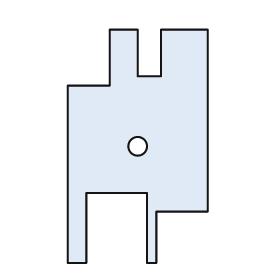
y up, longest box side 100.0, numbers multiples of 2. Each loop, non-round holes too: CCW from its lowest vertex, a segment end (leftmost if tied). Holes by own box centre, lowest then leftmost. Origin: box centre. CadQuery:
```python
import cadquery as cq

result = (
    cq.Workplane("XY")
    .moveTo(-30.0, -50.0)
    .lineTo(-22.0, -50.0)
    .lineTo(-22.0, -20.0)
    .lineTo(4.0, -20.0)
    .lineTo(4.0, -50.0)
    .lineTo(8.0, -50.0)
    .lineTo(8.0, -28.0)
    .lineTo(30.0, -28.0)
    .lineTo(30.0, 50.0)
    .lineTo(10.0, 50.0)
    .lineTo(10.0, 30.0)
    .lineTo(0.0, 30.0)
    .lineTo(0.0, 50.0)
    .lineTo(-12.0, 50.0)
    .lineTo(-12.0, 26.0)
    .lineTo(-30.0, 26.0)
    .close()
    .moveTo(0.0, 0.0)
    .circle(4.0)
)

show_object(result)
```